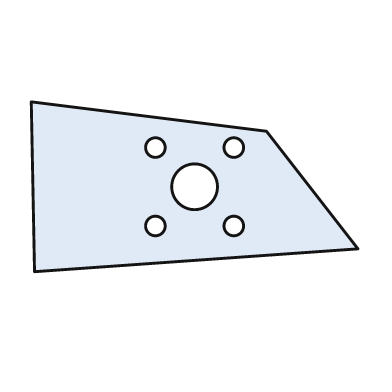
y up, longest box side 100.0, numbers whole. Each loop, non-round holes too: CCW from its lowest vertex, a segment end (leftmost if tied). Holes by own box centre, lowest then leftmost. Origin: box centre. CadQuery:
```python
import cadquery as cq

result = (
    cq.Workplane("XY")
    .moveTo(-49.0, -26.0)
    .lineTo(50.0, -19.0)
    .lineTo(22.0, 17.0)
    .lineTo(-50.0, 26.0)
    .close()
    .moveTo(-12.0, -12.0)
    .circle(3.0)
    .moveTo(12.0, -12.0)
    .circle(3.0)
    .moveTo(0.0, 0.0)
    .circle(7.0)
    .moveTo(-12.0, 12.0)
    .circle(3.0)
    .moveTo(12.0, 12.0)
    .circle(3.0)
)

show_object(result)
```